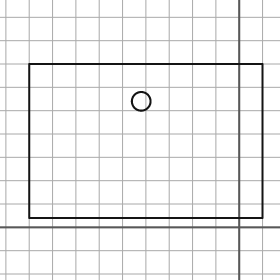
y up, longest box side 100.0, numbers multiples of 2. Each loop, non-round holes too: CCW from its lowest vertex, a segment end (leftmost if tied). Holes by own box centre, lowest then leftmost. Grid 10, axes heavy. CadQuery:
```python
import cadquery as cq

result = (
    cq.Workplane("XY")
    .moveTo(-90.0, 4.0)
    .lineTo(10.0, 4.0)
    .lineTo(10.0, 70.0)
    .lineTo(-90.0, 70.0)
    .close()
    .moveTo(-42.0, 54.0)
    .circle(4.0)
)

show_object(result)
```